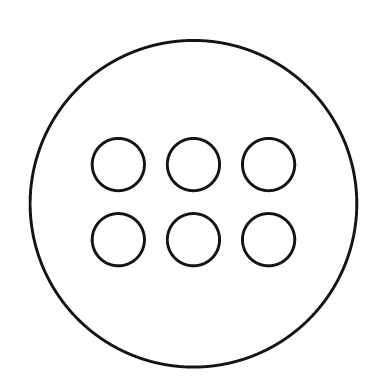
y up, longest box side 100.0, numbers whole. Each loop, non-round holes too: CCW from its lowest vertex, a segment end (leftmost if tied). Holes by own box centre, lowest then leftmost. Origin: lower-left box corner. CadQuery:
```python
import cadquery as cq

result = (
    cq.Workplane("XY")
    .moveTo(50.0, 50.0)
    .circle(50.0)
    .moveTo(27.0, 39.0)
    .circle(8.0)
    .moveTo(50.0, 39.0)
    .circle(8.0)
    .moveTo(73.0, 39.0)
    .circle(8.0)
    .moveTo(27.0, 62.0)
    .circle(8.0)
    .moveTo(50.0, 62.0)
    .circle(8.0)
    .moveTo(73.0, 62.0)
    .circle(8.0)
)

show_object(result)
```